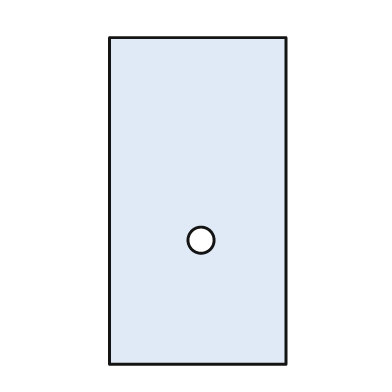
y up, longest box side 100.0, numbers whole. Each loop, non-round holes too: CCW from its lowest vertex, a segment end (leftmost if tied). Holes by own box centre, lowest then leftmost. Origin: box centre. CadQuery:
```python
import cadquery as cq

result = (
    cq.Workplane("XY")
    .moveTo(-27.0, -50.0)
    .lineTo(27.0, -50.0)
    .lineTo(27.0, 50.0)
    .lineTo(-27.0, 50.0)
    .close()
    .moveTo(1.0, -12.0)
    .circle(4.0)
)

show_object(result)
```